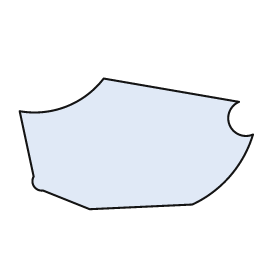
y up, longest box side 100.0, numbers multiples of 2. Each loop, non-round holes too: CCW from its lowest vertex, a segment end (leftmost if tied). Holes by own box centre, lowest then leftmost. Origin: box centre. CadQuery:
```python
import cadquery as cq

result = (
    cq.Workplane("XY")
    .moveTo(-20.0, -28.0)
    .lineTo(24.0, -26.0)
    .threePointArc((40.0, -14.0), (50.0, 4.0))
    .threePointArc((40.0, 8.0), (44.0, 18.0))
    .lineTo(-14.0, 28.0)
    .threePointArc((-30.0, 16.0), (-50.0, 14.0))
    .lineTo(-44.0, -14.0)
    .threePointArc((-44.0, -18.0), (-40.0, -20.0))
    .close()
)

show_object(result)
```